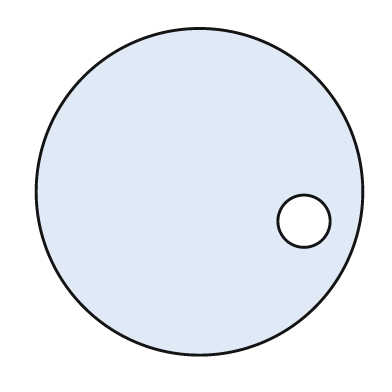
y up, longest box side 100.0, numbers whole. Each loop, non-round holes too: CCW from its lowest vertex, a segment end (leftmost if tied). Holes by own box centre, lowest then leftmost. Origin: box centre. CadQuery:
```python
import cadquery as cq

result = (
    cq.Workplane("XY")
    .moveTo(0.0, 0.0)
    .circle(50.0)
    .moveTo(32.0, -9.0)
    .circle(8.0)
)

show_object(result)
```